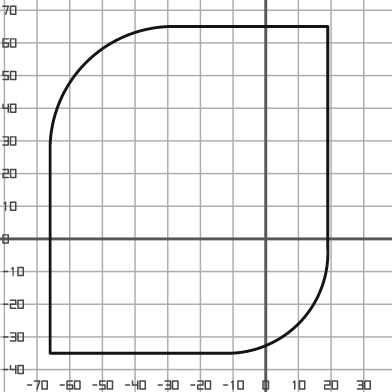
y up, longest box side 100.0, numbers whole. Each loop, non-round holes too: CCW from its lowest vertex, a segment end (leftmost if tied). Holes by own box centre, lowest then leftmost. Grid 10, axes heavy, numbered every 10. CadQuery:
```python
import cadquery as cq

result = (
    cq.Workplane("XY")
    .moveTo(-66.0, -35.0)
    .lineTo(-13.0, -35.0)
    .threePointArc((10.0, -26.0), (19.0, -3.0))
    .lineTo(19.0, 65.0)
    .lineTo(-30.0, 65.0)
    .threePointArc((-55.0, 54.0), (-66.0, 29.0))
    .close()
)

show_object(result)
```